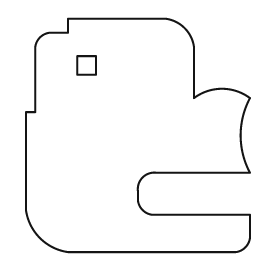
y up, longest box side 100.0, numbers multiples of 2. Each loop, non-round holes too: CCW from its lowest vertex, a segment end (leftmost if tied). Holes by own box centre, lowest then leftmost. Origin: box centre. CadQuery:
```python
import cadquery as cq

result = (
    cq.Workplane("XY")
    .moveTo(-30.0, -50.0)
    .lineTo(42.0, -50.0)
    .threePointArc((46.0, -48.0), (48.0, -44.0))
    .lineTo(48.0, -34.0)
    .lineTo(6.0, -34.0)
    .threePointArc((2.0, -32.0), (0.0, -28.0))
    .lineTo(0.0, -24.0)
    .threePointArc((2.0, -18.0), (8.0, -16.0))
    .lineTo(48.0, -16.0)
    .threePointArc((44.0, 0.0), (48.0, 16.0))
    .threePointArc((36.0, 20.0), (24.0, 16.0))
    .lineTo(24.0, 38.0)
    .threePointArc((20.0, 46.0), (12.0, 50.0))
    .lineTo(-30.0, 50.0)
    .lineTo(-30.0, 44.0)
    .lineTo(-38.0, 44.0)
    .threePointArc((-42.0, 42.0), (-44.0, 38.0))
    .lineTo(-44.0, 10.0)
    .lineTo(-48.0, 10.0)
    .lineTo(-48.0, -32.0)
    .threePointArc((-42.0, -44.0), (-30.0, -50.0))
    .close()
    .moveTo(-26.0, 26.0)
    .lineTo(-18.0, 26.0)
    .lineTo(-18.0, 34.0)
    .lineTo(-26.0, 34.0)
    .close()
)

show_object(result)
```